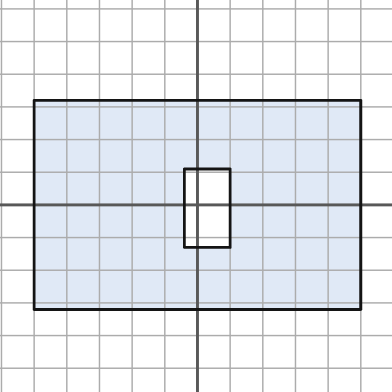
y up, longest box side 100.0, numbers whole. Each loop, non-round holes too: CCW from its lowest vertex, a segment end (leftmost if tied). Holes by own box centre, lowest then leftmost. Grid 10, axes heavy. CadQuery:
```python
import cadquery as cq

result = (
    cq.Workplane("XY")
    .moveTo(-50.0, -32.0)
    .lineTo(50.0, -32.0)
    .lineTo(50.0, 32.0)
    .lineTo(-50.0, 32.0)
    .close()
    .moveTo(-4.0, -13.0)
    .lineTo(10.0, -13.0)
    .lineTo(10.0, 11.0)
    .lineTo(-4.0, 11.0)
    .close()
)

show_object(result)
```